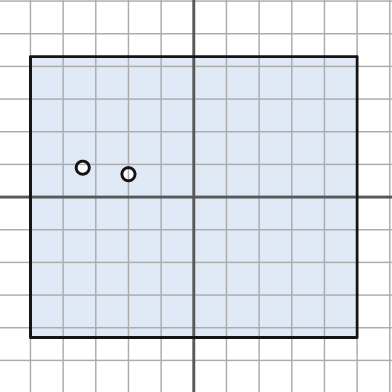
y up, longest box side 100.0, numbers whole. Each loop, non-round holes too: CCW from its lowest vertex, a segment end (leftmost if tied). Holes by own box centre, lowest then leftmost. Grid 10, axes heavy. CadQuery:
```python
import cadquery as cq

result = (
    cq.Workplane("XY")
    .moveTo(-50.0, -43.0)
    .lineTo(50.0, -43.0)
    .lineTo(50.0, 43.0)
    .lineTo(-50.0, 43.0)
    .close()
    .moveTo(-20.0, 7.0)
    .circle(2.0)
    .moveTo(-34.0, 9.0)
    .circle(2.0)
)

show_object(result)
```